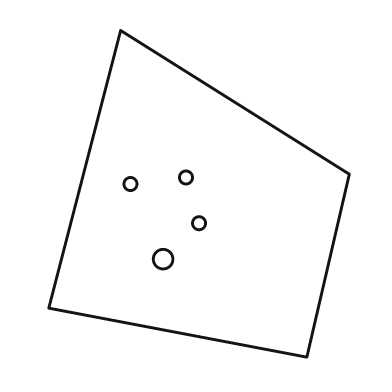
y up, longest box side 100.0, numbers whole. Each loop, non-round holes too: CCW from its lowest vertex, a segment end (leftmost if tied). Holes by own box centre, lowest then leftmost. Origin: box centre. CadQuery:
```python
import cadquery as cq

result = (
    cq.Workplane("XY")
    .moveTo(33.0, -50.0)
    .lineTo(46.0, 6.0)
    .lineTo(-24.0, 50.0)
    .lineTo(-46.0, -35.0)
    .close()
    .moveTo(-11.0, -20.0)
    .circle(3.0)
    .moveTo(0.0, -9.0)
    .circle(2.0)
    .moveTo(-21.0, 3.0)
    .circle(2.0)
    .moveTo(-4.0, 5.0)
    .circle(2.0)
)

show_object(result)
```